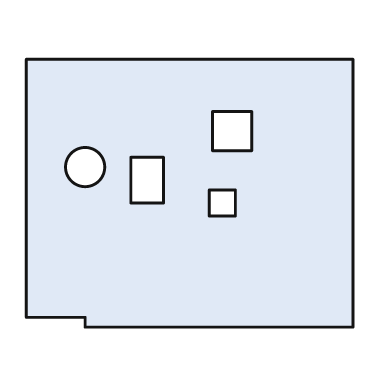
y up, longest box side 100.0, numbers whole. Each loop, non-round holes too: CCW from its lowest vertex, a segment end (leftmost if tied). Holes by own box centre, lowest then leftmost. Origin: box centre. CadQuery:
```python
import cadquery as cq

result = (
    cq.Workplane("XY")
    .moveTo(-32.0, -41.0)
    .lineTo(50.0, -41.0)
    .lineTo(50.0, 41.0)
    .lineTo(-50.0, 41.0)
    .lineTo(-50.0, -38.0)
    .lineTo(-32.0, -38.0)
    .close()
    .moveTo(6.0, -7.0)
    .lineTo(14.0, -7.0)
    .lineTo(14.0, 1.0)
    .lineTo(6.0, 1.0)
    .close()
    .moveTo(-18.0, -3.0)
    .lineTo(-8.0, -3.0)
    .lineTo(-8.0, 11.0)
    .lineTo(-18.0, 11.0)
    .close()
    .moveTo(-32.0, 8.0)
    .circle(6.0)
    .moveTo(7.0, 13.0)
    .lineTo(19.0, 13.0)
    .lineTo(19.0, 25.0)
    .lineTo(7.0, 25.0)
    .close()
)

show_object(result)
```